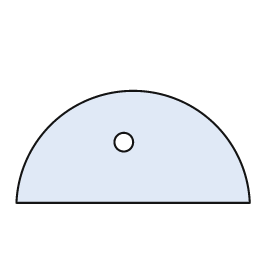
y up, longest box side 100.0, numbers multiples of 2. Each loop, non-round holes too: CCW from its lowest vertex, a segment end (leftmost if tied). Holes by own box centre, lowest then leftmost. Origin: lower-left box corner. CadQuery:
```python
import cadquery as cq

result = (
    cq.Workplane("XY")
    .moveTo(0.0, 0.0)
    .lineTo(100.0, 0.0)
    .threePointArc((50.0, 48.0), (0.0, 0.0))
    .close()
    .moveTo(46.0, 26.0)
    .circle(4.0)
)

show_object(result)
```